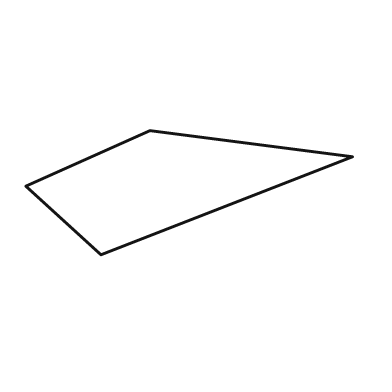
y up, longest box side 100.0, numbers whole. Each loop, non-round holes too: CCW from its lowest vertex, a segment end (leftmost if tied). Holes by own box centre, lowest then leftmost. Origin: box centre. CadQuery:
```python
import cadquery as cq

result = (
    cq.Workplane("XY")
    .moveTo(-27.0, -19.0)
    .lineTo(50.0, 11.0)
    .lineTo(-12.0, 19.0)
    .lineTo(-50.0, 2.0)
    .close()
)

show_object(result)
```